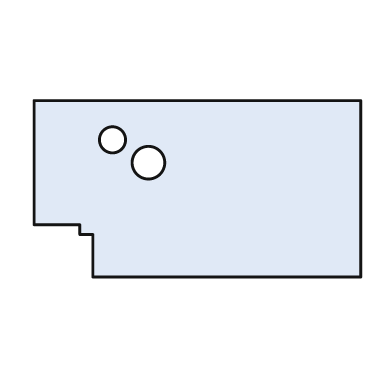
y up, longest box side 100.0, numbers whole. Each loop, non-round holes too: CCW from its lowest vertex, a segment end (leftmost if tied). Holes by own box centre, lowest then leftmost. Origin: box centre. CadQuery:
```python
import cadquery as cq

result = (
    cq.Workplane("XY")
    .moveTo(-32.0, -27.0)
    .lineTo(50.0, -27.0)
    .lineTo(50.0, 27.0)
    .lineTo(-50.0, 27.0)
    .lineTo(-50.0, -11.0)
    .lineTo(-36.0, -11.0)
    .lineTo(-36.0, -14.0)
    .lineTo(-32.0, -14.0)
    .close()
    .moveTo(-15.0, 8.0)
    .circle(5.0)
    .moveTo(-26.0, 15.0)
    .circle(4.0)
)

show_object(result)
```